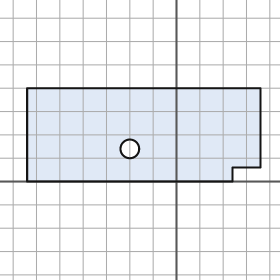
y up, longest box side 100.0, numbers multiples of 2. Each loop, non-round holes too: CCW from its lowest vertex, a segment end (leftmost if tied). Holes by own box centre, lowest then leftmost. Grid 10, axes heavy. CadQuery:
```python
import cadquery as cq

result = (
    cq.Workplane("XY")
    .moveTo(-64.0, 0.0)
    .lineTo(24.0, 0.0)
    .lineTo(24.0, 6.0)
    .lineTo(36.0, 6.0)
    .lineTo(36.0, 40.0)
    .lineTo(-64.0, 40.0)
    .close()
    .moveTo(-20.0, 14.0)
    .circle(4.0)
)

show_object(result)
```